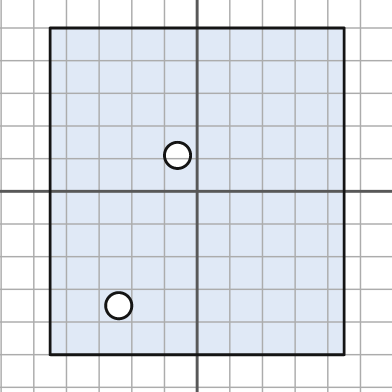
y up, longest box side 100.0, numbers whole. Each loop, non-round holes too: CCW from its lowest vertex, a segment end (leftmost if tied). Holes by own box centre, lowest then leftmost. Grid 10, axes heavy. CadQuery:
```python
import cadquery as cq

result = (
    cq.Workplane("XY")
    .moveTo(-45.0, -50.0)
    .lineTo(45.0, -50.0)
    .lineTo(45.0, 50.0)
    .lineTo(-45.0, 50.0)
    .close()
    .moveTo(-24.0, -35.0)
    .circle(4.0)
    .moveTo(-6.0, 11.0)
    .circle(4.0)
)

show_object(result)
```